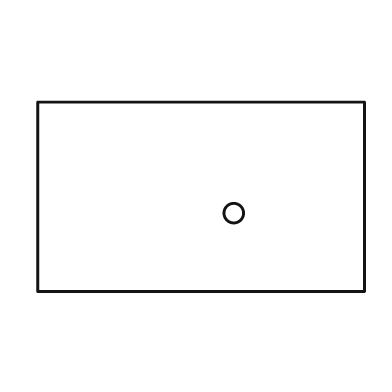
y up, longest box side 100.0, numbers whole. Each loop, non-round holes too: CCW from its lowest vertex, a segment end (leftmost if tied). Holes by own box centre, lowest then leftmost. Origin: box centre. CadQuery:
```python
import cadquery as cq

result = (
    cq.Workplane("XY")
    .moveTo(-50.0, -29.0)
    .lineTo(50.0, -29.0)
    .lineTo(50.0, 29.0)
    .lineTo(-50.0, 29.0)
    .close()
    .moveTo(10.0, -5.0)
    .circle(3.0)
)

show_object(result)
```